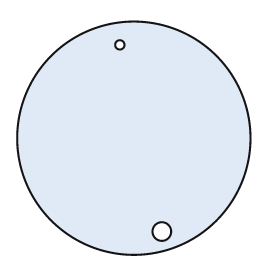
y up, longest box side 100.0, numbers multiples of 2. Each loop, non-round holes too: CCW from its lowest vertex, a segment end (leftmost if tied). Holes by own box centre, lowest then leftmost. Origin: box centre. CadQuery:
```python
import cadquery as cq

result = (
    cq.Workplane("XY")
    .moveTo(0.0, 0.0)
    .circle(50.0)
    .moveTo(12.0, -40.0)
    .circle(4.0)
    .moveTo(-6.0, 40.0)
    .circle(2.0)
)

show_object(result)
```